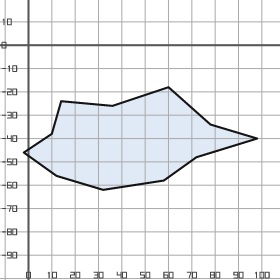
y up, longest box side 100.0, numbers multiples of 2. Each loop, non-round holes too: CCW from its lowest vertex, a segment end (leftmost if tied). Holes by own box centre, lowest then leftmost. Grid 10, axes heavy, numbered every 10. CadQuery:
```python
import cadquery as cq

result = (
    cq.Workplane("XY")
    .moveTo(32.0, -62.0)
    .lineTo(58.0, -58.0)
    .lineTo(72.0, -48.0)
    .lineTo(98.0, -40.0)
    .lineTo(78.0, -34.0)
    .lineTo(60.0, -18.0)
    .lineTo(36.0, -26.0)
    .lineTo(14.0, -24.0)
    .lineTo(10.0, -38.0)
    .lineTo(-2.0, -46.0)
    .lineTo(12.0, -56.0)
    .close()
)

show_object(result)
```